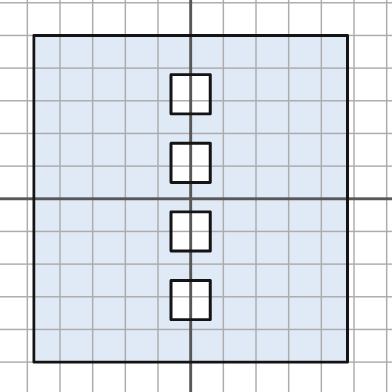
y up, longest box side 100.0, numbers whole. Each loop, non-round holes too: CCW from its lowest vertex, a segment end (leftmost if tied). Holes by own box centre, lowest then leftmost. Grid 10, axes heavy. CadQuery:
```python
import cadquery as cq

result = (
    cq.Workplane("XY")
    .moveTo(-48.0, -50.0)
    .lineTo(48.0, -50.0)
    .lineTo(48.0, 50.0)
    .lineTo(-48.0, 50.0)
    .close()
    .moveTo(-6.0, -37.0)
    .lineTo(6.0, -37.0)
    .lineTo(6.0, -25.0)
    .lineTo(-6.0, -25.0)
    .close()
    .moveTo(-6.0, -16.0)
    .lineTo(6.0, -16.0)
    .lineTo(6.0, -4.0)
    .lineTo(-6.0, -4.0)
    .close()
    .moveTo(-6.0, 5.0)
    .lineTo(6.0, 5.0)
    .lineTo(6.0, 17.0)
    .lineTo(-6.0, 17.0)
    .close()
    .moveTo(-6.0, 26.0)
    .lineTo(6.0, 26.0)
    .lineTo(6.0, 38.0)
    .lineTo(-6.0, 38.0)
    .close()
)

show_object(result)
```